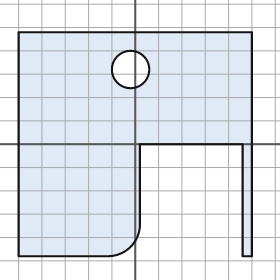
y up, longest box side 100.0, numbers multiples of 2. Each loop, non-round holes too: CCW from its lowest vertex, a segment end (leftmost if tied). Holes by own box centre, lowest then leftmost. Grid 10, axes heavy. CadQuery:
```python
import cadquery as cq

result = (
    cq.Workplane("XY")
    .moveTo(-50.0, -48.0)
    .lineTo(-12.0, -48.0)
    .threePointArc((-2.0, -44.0), (2.0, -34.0))
    .lineTo(2.0, 0.0)
    .lineTo(46.0, 0.0)
    .lineTo(46.0, -48.0)
    .lineTo(50.0, -48.0)
    .lineTo(50.0, 48.0)
    .lineTo(-50.0, 48.0)
    .close()
    .moveTo(-2.0, 32.0)
    .circle(8.0)
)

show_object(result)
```